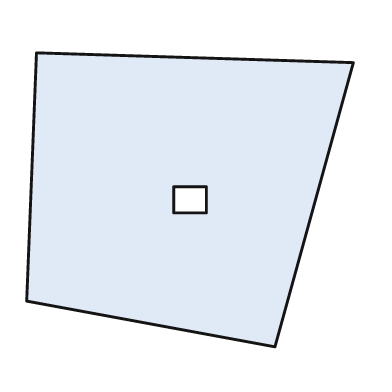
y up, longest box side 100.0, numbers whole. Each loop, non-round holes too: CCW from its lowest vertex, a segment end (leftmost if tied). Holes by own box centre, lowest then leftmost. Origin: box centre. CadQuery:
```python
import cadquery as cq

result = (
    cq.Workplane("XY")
    .moveTo(26.0, -45.0)
    .lineTo(50.0, 42.0)
    .lineTo(-47.0, 45.0)
    .lineTo(-50.0, -31.0)
    .close()
    .moveTo(-5.0, -4.0)
    .lineTo(5.0, -4.0)
    .lineTo(5.0, 4.0)
    .lineTo(-5.0, 4.0)
    .close()
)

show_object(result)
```